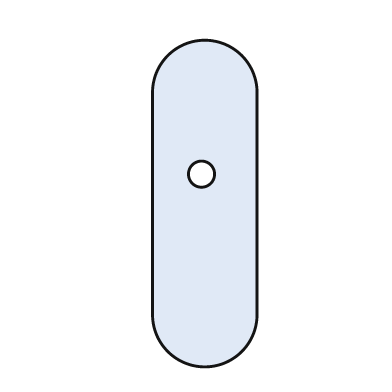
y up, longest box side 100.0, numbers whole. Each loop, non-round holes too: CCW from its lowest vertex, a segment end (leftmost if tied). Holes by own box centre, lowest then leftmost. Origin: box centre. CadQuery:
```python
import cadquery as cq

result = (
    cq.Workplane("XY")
    .moveTo(-16.0, -34.0)
    .threePointArc((0.0, -50.0), (16.0, -34.0))
    .lineTo(16.0, 34.0)
    .threePointArc((0.0, 50.0), (-16.0, 34.0))
    .close()
    .moveTo(-1.0, 9.0)
    .circle(4.0)
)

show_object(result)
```